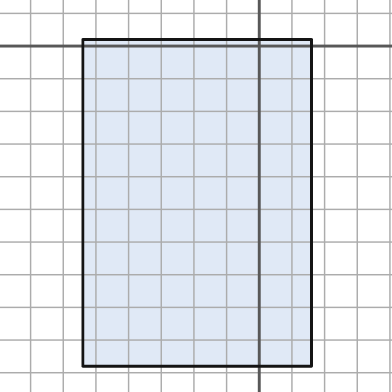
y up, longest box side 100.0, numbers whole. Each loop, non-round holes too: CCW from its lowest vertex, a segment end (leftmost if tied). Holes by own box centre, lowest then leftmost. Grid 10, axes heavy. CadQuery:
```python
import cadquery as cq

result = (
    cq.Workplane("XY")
    .moveTo(-54.0, -98.0)
    .lineTo(16.0, -98.0)
    .lineTo(16.0, 2.0)
    .lineTo(-54.0, 2.0)
    .close()
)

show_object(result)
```